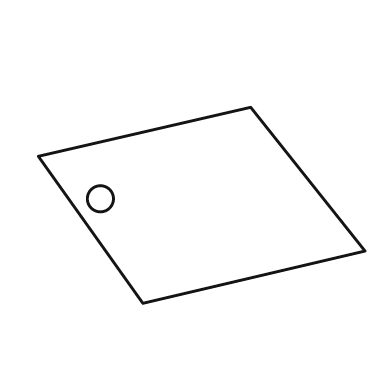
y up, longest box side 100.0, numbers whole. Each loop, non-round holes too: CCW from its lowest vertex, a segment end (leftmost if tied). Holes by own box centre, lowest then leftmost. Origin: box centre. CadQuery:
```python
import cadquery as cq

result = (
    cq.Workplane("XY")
    .moveTo(-18.0, -30.0)
    .lineTo(50.0, -14.0)
    .lineTo(15.0, 30.0)
    .lineTo(-50.0, 15.0)
    .close()
    .moveTo(-31.0, 2.0)
    .circle(4.0)
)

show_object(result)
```